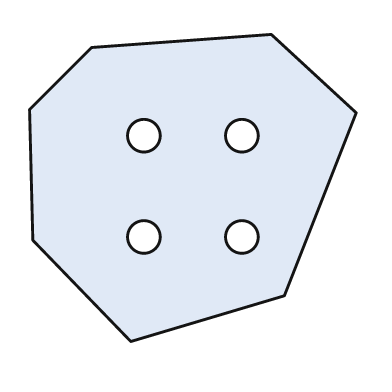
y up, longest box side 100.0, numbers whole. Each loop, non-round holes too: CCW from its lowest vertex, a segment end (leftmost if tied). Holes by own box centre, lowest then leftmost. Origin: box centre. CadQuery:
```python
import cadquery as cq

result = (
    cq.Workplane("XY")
    .moveTo(-19.0, -47.0)
    .lineTo(28.0, -33.0)
    .lineTo(50.0, 23.0)
    .lineTo(24.0, 47.0)
    .lineTo(-31.0, 43.0)
    .lineTo(-50.0, 24.0)
    .lineTo(-49.0, -16.0)
    .close()
    .moveTo(-15.0, -15.0)
    .circle(5.0)
    .moveTo(15.0, -15.0)
    .circle(5.0)
    .moveTo(-15.0, 16.0)
    .circle(5.0)
    .moveTo(15.0, 16.0)
    .circle(5.0)
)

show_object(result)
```